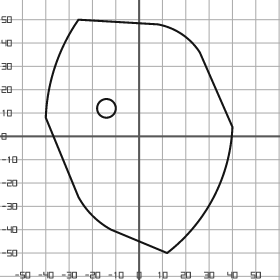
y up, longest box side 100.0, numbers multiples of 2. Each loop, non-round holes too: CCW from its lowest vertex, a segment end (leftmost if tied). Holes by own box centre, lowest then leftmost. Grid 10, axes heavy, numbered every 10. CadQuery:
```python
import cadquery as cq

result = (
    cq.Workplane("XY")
    .moveTo(12.0, -50.0)
    .threePointArc((32.0, -26.0), (40.0, 4.0))
    .lineTo(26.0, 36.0)
    .threePointArc((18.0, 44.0), (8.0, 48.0))
    .lineTo(-26.0, 50.0)
    .threePointArc((-36.0, 30.0), (-40.0, 8.0))
    .lineTo(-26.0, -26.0)
    .threePointArc((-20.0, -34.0), (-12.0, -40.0))
    .close()
    .moveTo(-14.0, 12.0)
    .circle(4.0)
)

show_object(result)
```